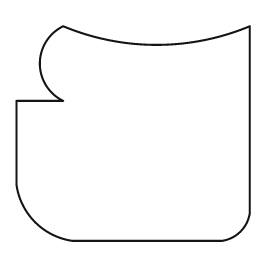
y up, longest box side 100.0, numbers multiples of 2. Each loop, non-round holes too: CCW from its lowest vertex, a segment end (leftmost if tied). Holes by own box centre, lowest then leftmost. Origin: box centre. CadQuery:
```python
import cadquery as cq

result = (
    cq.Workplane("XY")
    .moveTo(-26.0, -46.0)
    .lineTo(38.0, -46.0)
    .threePointArc((46.0, -42.0), (50.0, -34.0))
    .lineTo(50.0, 46.0)
    .threePointArc((10.0, 38.0), (-30.0, 46.0))
    .threePointArc((-40.0, 30.0), (-30.0, 14.0))
    .lineTo(-50.0, 14.0)
    .lineTo(-50.0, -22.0)
    .threePointArc((-42.0, -38.0), (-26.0, -46.0))
    .close()
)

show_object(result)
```